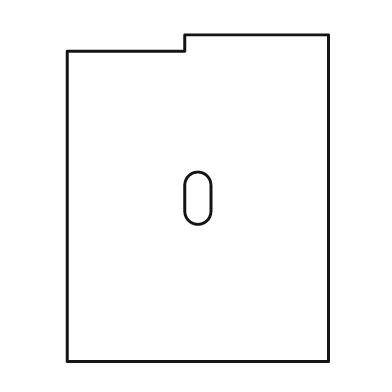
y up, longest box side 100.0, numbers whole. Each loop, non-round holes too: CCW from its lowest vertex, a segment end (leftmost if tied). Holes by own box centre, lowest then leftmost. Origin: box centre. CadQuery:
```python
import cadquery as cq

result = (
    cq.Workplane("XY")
    .moveTo(-40.0, -50.0)
    .lineTo(40.0, -50.0)
    .lineTo(40.0, 50.0)
    .lineTo(-4.0, 50.0)
    .lineTo(-4.0, 45.0)
    .lineTo(-40.0, 45.0)
    .close()
    .moveTo(-4.0, -4.0)
    .threePointArc((0.0, -8.0), (4.0, -4.0))
    .lineTo(4.0, 4.0)
    .threePointArc((0.0, 8.0), (-4.0, 4.0))
    .close()
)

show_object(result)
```